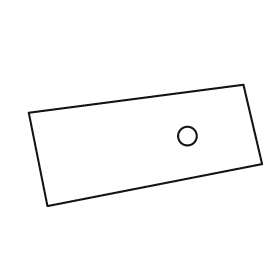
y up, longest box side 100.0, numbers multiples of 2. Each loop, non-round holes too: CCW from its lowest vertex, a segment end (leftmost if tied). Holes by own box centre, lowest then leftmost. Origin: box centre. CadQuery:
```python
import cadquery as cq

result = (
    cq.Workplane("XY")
    .moveTo(-42.0, -26.0)
    .lineTo(50.0, -8.0)
    .lineTo(42.0, 26.0)
    .lineTo(-50.0, 14.0)
    .close()
    .moveTo(18.0, 4.0)
    .circle(4.0)
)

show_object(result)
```